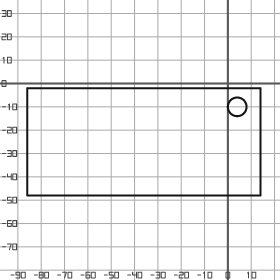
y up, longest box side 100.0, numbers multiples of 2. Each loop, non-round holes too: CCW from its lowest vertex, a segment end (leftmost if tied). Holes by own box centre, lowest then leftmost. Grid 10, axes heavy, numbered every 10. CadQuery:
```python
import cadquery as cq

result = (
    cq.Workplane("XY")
    .moveTo(-86.0, -48.0)
    .lineTo(14.0, -48.0)
    .lineTo(14.0, -2.0)
    .lineTo(-86.0, -2.0)
    .close()
    .moveTo(4.0, -10.0)
    .circle(4.0)
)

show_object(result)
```